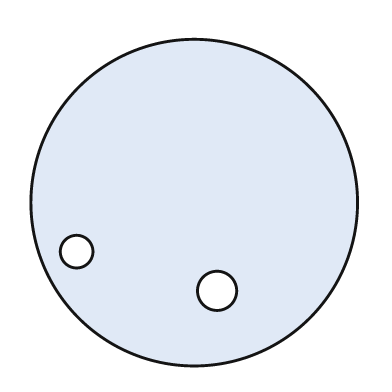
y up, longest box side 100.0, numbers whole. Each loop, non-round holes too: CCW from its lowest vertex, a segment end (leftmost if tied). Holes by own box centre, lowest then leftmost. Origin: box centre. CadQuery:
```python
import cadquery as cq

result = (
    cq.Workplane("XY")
    .moveTo(0.0, 0.0)
    .circle(50.0)
    .moveTo(7.0, -27.0)
    .circle(6.0)
    .moveTo(-36.0, -15.0)
    .circle(5.0)
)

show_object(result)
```